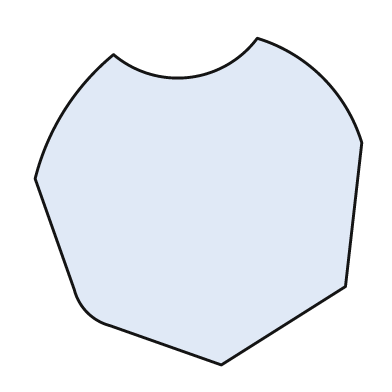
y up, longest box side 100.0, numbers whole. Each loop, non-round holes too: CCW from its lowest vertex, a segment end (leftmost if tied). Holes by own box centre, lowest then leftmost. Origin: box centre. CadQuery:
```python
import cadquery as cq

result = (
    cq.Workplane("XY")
    .moveTo(7.0, -50.0)
    .lineTo(45.0, -26.0)
    .lineTo(50.0, 18.0)
    .threePointArc((38.0, 38.0), (18.0, 50.0))
    .threePointArc((-3.0, 38.0), (-26.0, 45.0))
    .threePointArc((-41.0, 28.0), (-50.0, 7.0))
    .lineTo(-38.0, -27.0)
    .threePointArc((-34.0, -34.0), (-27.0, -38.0))
    .close()
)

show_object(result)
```